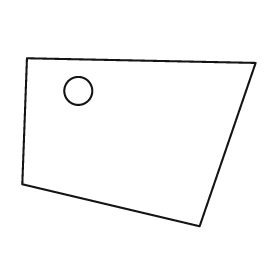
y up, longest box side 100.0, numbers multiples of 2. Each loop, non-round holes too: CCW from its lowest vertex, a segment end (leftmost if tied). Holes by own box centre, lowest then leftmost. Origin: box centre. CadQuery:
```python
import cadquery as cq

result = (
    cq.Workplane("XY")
    .moveTo(26.0, -36.0)
    .lineTo(50.0, 34.0)
    .lineTo(-48.0, 36.0)
    .lineTo(-50.0, -18.0)
    .close()
    .moveTo(-26.0, 22.0)
    .circle(6.0)
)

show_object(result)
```